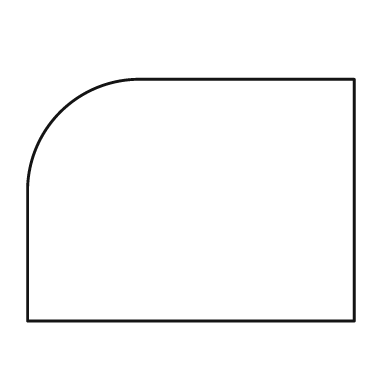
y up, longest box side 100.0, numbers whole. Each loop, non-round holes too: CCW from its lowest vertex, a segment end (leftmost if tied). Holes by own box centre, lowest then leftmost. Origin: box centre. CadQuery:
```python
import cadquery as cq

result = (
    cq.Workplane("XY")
    .moveTo(-50.0, -37.0)
    .lineTo(50.0, -37.0)
    .lineTo(50.0, 37.0)
    .lineTo(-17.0, 37.0)
    .threePointArc((-40.0, 27.0), (-50.0, 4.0))
    .close()
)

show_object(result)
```